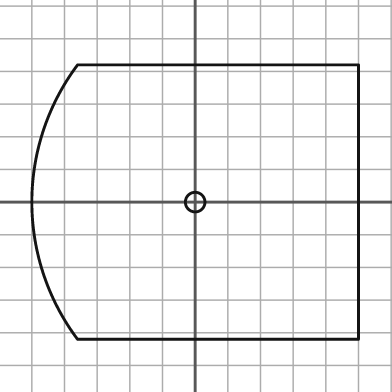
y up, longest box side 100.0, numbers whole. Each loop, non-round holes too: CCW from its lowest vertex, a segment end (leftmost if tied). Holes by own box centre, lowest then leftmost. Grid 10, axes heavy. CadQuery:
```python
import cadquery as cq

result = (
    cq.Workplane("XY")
    .moveTo(-36.0, -42.0)
    .lineTo(50.0, -42.0)
    .lineTo(50.0, 42.0)
    .lineTo(-36.0, 42.0)
    .threePointArc((-50.0, 0.0), (-36.0, -42.0))
    .close()
    .moveTo(0.0, 0.0)
    .circle(3.0)
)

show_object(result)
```